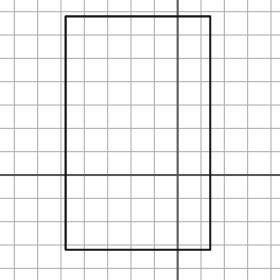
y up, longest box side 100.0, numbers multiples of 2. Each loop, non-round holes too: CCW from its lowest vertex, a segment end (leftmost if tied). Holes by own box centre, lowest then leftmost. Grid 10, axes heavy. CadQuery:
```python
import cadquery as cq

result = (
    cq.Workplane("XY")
    .moveTo(-48.0, -32.0)
    .lineTo(14.0, -32.0)
    .lineTo(14.0, 68.0)
    .lineTo(-48.0, 68.0)
    .close()
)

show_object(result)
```